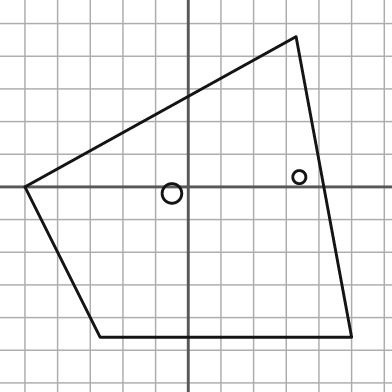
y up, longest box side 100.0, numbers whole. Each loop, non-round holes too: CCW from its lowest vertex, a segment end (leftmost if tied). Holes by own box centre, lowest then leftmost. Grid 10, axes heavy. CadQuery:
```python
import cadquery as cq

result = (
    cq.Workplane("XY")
    .moveTo(-27.0, -46.0)
    .lineTo(50.0, -46.0)
    .lineTo(33.0, 46.0)
    .lineTo(-50.0, 0.0)
    .close()
    .moveTo(-5.0, -2.0)
    .circle(3.0)
    .moveTo(34.0, 3.0)
    .circle(2.0)
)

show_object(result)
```